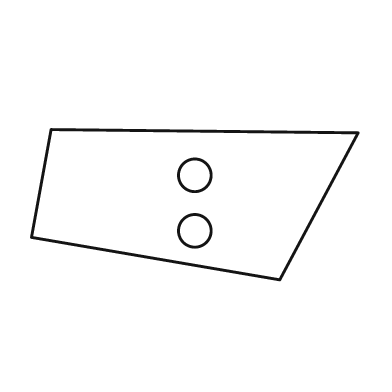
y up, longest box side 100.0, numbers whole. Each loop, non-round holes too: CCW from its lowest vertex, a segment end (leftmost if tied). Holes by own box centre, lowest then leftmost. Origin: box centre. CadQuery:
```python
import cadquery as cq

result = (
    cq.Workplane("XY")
    .moveTo(26.0, -23.0)
    .lineTo(50.0, 22.0)
    .lineTo(-44.0, 23.0)
    .lineTo(-50.0, -10.0)
    .close()
    .moveTo(0.0, -8.0)
    .circle(5.0)
    .moveTo(0.0, 9.0)
    .circle(5.0)
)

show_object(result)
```